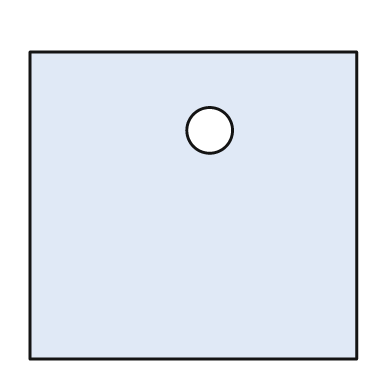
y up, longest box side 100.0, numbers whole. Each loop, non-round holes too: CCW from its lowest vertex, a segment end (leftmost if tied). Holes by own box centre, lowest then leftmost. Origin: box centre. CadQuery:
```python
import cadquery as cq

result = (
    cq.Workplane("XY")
    .moveTo(-50.0, -47.0)
    .lineTo(50.0, -47.0)
    .lineTo(50.0, 47.0)
    .lineTo(-50.0, 47.0)
    .close()
    .moveTo(5.0, 23.0)
    .circle(7.0)
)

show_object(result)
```